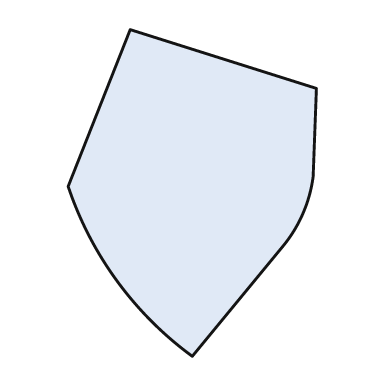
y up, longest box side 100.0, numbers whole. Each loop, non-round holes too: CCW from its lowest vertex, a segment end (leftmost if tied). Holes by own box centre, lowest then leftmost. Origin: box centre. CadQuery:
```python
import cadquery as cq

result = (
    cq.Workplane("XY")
    .moveTo(0.0, -50.0)
    .lineTo(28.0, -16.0)
    .threePointArc((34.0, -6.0), (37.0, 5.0))
    .lineTo(38.0, 32.0)
    .lineTo(-19.0, 50.0)
    .lineTo(-38.0, 2.0)
    .threePointArc((-23.0, -27.0), (0.0, -50.0))
    .close()
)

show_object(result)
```